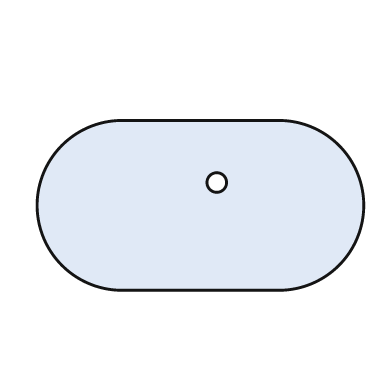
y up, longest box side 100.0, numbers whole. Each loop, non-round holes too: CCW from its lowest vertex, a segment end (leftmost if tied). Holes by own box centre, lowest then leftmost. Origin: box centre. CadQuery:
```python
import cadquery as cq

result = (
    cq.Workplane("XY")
    .moveTo(-24.0, -26.0)
    .lineTo(24.0, -26.0)
    .threePointArc((50.0, 0.0), (24.0, 26.0))
    .lineTo(-24.0, 26.0)
    .threePointArc((-50.0, 0.0), (-24.0, -26.0))
    .close()
    .moveTo(5.0, 7.0)
    .circle(3.0)
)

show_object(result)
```